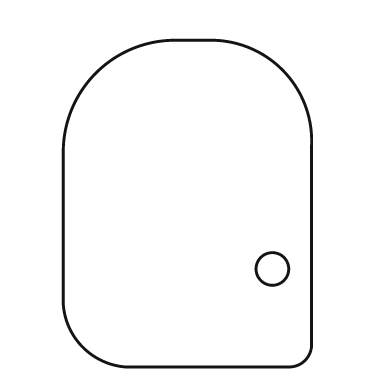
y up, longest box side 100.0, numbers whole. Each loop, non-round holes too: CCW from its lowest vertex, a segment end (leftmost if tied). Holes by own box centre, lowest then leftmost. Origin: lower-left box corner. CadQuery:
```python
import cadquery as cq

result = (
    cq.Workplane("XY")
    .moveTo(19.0, 0.0)
    .lineTo(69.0, 0.0)
    .threePointArc((74.0, 2.0), (76.0, 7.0))
    .lineTo(76.0, 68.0)
    .threePointArc((67.0, 91.0), (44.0, 100.0))
    .lineTo(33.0, 100.0)
    .threePointArc((10.0, 90.0), (0.0, 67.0))
    .lineTo(0.0, 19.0)
    .threePointArc((6.0, 6.0), (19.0, 0.0))
    .close()
    .moveTo(64.0, 30.0)
    .circle(5.0)
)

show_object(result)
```